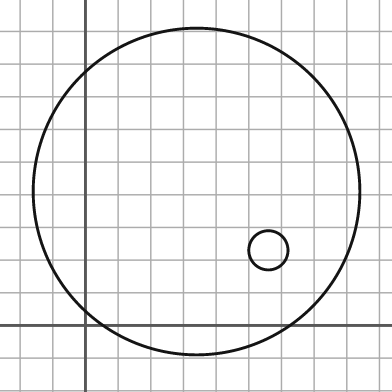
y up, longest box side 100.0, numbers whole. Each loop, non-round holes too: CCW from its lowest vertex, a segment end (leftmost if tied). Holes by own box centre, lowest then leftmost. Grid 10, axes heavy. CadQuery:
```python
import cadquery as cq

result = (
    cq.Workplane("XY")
    .moveTo(34.0, 41.0)
    .circle(50.0)
    .moveTo(56.0, 23.0)
    .circle(6.0)
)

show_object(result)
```